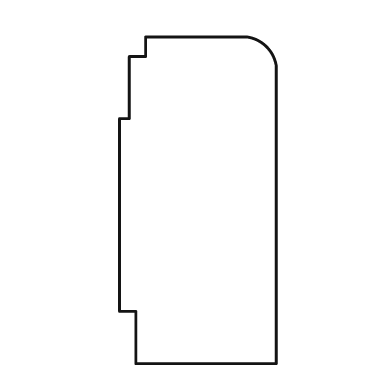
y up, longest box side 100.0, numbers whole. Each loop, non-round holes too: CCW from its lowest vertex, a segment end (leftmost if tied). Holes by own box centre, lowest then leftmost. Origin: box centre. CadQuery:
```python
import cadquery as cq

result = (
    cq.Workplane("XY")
    .moveTo(-19.0, -50.0)
    .lineTo(24.0, -50.0)
    .lineTo(24.0, 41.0)
    .threePointArc((21.0, 47.0), (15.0, 50.0))
    .lineTo(-16.0, 50.0)
    .lineTo(-16.0, 44.0)
    .lineTo(-21.0, 44.0)
    .lineTo(-21.0, 25.0)
    .lineTo(-24.0, 25.0)
    .lineTo(-24.0, -34.0)
    .lineTo(-19.0, -34.0)
    .close()
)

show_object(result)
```